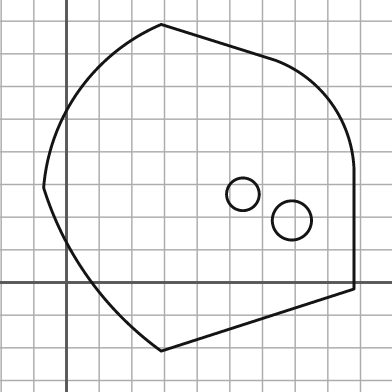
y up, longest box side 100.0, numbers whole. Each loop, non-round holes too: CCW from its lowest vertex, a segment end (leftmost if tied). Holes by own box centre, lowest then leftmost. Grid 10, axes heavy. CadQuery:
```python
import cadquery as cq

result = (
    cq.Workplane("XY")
    .moveTo(29.0, -21.0)
    .lineTo(88.0, -2.0)
    .lineTo(88.0, 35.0)
    .threePointArc((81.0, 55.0), (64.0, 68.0))
    .lineTo(29.0, 79.0)
    .threePointArc((4.0, 59.0), (-7.0, 29.0))
    .threePointArc((7.0, 1.0), (29.0, -21.0))
    .close()
    .moveTo(69.0, 19.0)
    .circle(6.0)
    .moveTo(54.0, 27.0)
    .circle(5.0)
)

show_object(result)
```